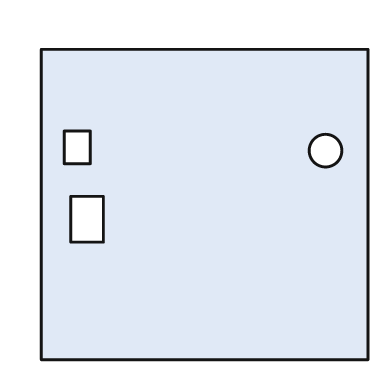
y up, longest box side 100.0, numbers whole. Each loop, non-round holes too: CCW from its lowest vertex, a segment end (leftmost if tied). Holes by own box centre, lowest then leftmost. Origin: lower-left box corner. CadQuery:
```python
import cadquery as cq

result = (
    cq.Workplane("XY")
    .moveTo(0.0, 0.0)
    .lineTo(100.0, 0.0)
    .lineTo(100.0, 95.0)
    .lineTo(0.0, 95.0)
    .close()
    .moveTo(9.0, 36.0)
    .lineTo(19.0, 36.0)
    .lineTo(19.0, 50.0)
    .lineTo(9.0, 50.0)
    .close()
    .moveTo(87.0, 64.0)
    .circle(5.0)
    .moveTo(7.0, 60.0)
    .lineTo(15.0, 60.0)
    .lineTo(15.0, 70.0)
    .lineTo(7.0, 70.0)
    .close()
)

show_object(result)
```